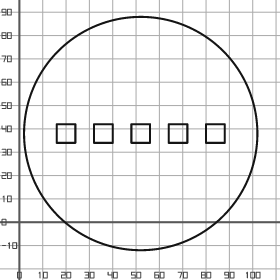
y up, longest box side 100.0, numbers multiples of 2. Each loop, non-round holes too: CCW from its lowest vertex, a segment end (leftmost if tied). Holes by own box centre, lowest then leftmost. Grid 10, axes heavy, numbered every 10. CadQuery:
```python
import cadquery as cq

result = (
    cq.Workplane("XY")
    .moveTo(52.0, 38.0)
    .circle(50.0)
    .moveTo(16.0, 34.0)
    .lineTo(24.0, 34.0)
    .lineTo(24.0, 42.0)
    .lineTo(16.0, 42.0)
    .close()
    .moveTo(32.0, 34.0)
    .lineTo(40.0, 34.0)
    .lineTo(40.0, 42.0)
    .lineTo(32.0, 42.0)
    .close()
    .moveTo(48.0, 34.0)
    .lineTo(56.0, 34.0)
    .lineTo(56.0, 42.0)
    .lineTo(48.0, 42.0)
    .close()
    .moveTo(64.0, 34.0)
    .lineTo(72.0, 34.0)
    .lineTo(72.0, 42.0)
    .lineTo(64.0, 42.0)
    .close()
    .moveTo(80.0, 34.0)
    .lineTo(88.0, 34.0)
    .lineTo(88.0, 42.0)
    .lineTo(80.0, 42.0)
    .close()
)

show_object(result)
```